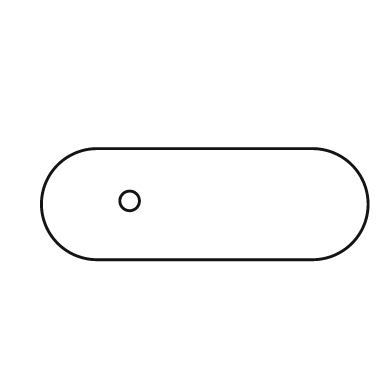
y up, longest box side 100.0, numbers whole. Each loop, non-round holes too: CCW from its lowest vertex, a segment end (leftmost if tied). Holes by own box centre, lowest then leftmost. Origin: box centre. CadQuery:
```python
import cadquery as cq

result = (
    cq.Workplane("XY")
    .moveTo(-33.0, -17.0)
    .lineTo(33.0, -17.0)
    .threePointArc((50.0, 0.0), (33.0, 17.0))
    .lineTo(-33.0, 17.0)
    .threePointArc((-50.0, 0.0), (-33.0, -17.0))
    .close()
    .moveTo(-23.0, 1.0)
    .circle(3.0)
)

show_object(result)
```